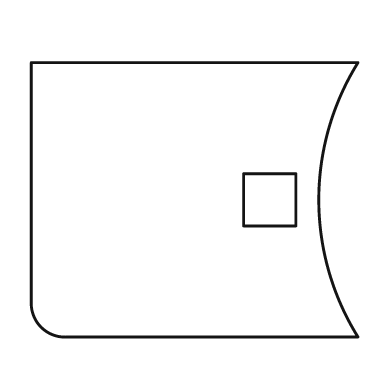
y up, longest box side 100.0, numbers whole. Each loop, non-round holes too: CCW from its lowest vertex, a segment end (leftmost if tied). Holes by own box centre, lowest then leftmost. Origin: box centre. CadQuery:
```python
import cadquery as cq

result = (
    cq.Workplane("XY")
    .moveTo(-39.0, -42.0)
    .lineTo(50.0, -42.0)
    .threePointArc((38.0, 0.0), (50.0, 42.0))
    .lineTo(-50.0, 42.0)
    .lineTo(-50.0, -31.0)
    .threePointArc((-47.0, -39.0), (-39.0, -42.0))
    .close()
    .moveTo(15.0, -8.0)
    .lineTo(31.0, -8.0)
    .lineTo(31.0, 8.0)
    .lineTo(15.0, 8.0)
    .close()
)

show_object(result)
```